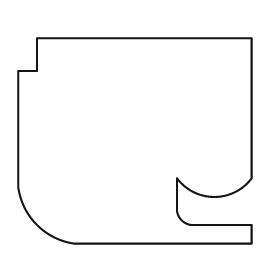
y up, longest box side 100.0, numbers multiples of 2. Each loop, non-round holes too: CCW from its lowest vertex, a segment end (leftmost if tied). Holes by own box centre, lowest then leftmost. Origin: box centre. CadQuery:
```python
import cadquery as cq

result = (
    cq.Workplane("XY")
    .moveTo(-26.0, -44.0)
    .lineTo(50.0, -44.0)
    .lineTo(50.0, -36.0)
    .lineTo(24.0, -36.0)
    .threePointArc((20.0, -34.0), (18.0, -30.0))
    .lineTo(18.0, -16.0)
    .threePointArc((34.0, -24.0), (50.0, -16.0))
    .lineTo(50.0, 44.0)
    .lineTo(-42.0, 44.0)
    .lineTo(-42.0, 30.0)
    .lineTo(-50.0, 30.0)
    .lineTo(-50.0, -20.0)
    .threePointArc((-42.0, -36.0), (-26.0, -44.0))
    .close()
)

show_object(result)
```